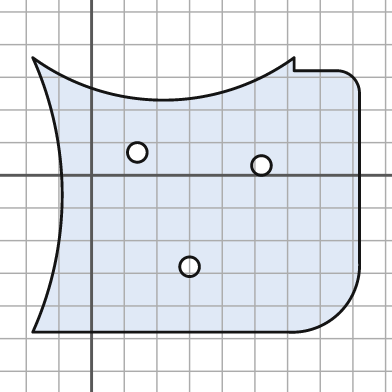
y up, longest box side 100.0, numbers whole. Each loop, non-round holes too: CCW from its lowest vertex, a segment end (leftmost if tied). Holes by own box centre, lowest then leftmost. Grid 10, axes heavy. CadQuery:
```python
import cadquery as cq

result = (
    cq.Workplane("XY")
    .moveTo(-18.0, -48.0)
    .lineTo(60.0, -48.0)
    .threePointArc((76.0, -42.0), (82.0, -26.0))
    .lineTo(82.0, 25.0)
    .threePointArc((80.0, 30.0), (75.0, 32.0))
    .lineTo(62.0, 32.0)
    .lineTo(62.0, 36.0)
    .threePointArc((22.0, 23.0), (-18.0, 36.0))
    .threePointArc((-9.0, -6.0), (-18.0, -48.0))
    .close()
    .moveTo(30.0, -28.0)
    .circle(3.0)
    .moveTo(52.0, 3.0)
    .circle(3.0)
    .moveTo(14.0, 7.0)
    .circle(3.0)
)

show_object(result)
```